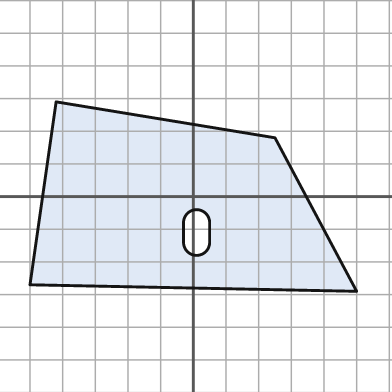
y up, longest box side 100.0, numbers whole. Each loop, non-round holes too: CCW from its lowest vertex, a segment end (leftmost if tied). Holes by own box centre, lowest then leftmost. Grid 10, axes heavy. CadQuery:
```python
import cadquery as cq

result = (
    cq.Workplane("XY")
    .moveTo(50.0, -29.0)
    .lineTo(25.0, 18.0)
    .lineTo(-42.0, 29.0)
    .lineTo(-50.0, -27.0)
    .close()
    .moveTo(-3.0, -14.0)
    .threePointArc((1.0, -18.0), (5.0, -14.0))
    .lineTo(5.0, -8.0)
    .threePointArc((1.0, -4.0), (-3.0, -8.0))
    .close()
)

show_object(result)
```